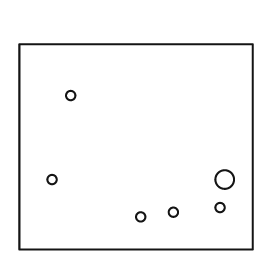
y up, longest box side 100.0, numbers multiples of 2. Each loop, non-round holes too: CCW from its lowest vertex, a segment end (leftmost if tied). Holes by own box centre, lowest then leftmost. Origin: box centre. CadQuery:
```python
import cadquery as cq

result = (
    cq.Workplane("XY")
    .moveTo(-50.0, -44.0)
    .lineTo(50.0, -44.0)
    .lineTo(50.0, 44.0)
    .lineTo(-50.0, 44.0)
    .close()
    .moveTo(2.0, -30.0)
    .circle(2.0)
    .moveTo(16.0, -28.0)
    .circle(2.0)
    .moveTo(36.0, -26.0)
    .circle(2.0)
    .moveTo(-36.0, -14.0)
    .circle(2.0)
    .moveTo(38.0, -14.0)
    .circle(4.0)
    .moveTo(-28.0, 22.0)
    .circle(2.0)
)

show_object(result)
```